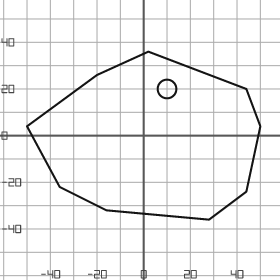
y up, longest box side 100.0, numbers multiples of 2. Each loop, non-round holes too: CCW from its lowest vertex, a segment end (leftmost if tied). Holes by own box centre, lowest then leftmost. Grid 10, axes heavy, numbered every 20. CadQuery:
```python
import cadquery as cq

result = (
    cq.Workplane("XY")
    .moveTo(28.0, -36.0)
    .lineTo(44.0, -24.0)
    .lineTo(50.0, 4.0)
    .lineTo(44.0, 20.0)
    .lineTo(2.0, 36.0)
    .lineTo(-20.0, 26.0)
    .lineTo(-50.0, 4.0)
    .lineTo(-36.0, -22.0)
    .lineTo(-16.0, -32.0)
    .close()
    .moveTo(10.0, 20.0)
    .circle(4.0)
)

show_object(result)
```